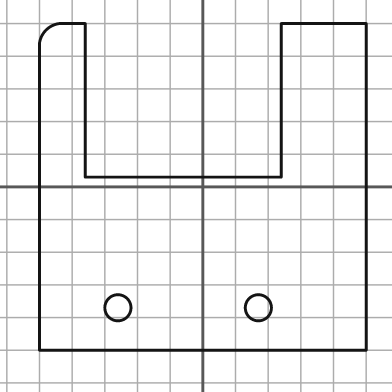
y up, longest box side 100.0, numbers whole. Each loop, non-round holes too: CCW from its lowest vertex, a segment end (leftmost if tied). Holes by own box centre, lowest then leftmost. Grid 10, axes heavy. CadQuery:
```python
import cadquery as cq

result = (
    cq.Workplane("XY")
    .moveTo(-50.0, -50.0)
    .lineTo(50.0, -50.0)
    .lineTo(50.0, 50.0)
    .lineTo(24.0, 50.0)
    .lineTo(24.0, 3.0)
    .lineTo(-36.0, 3.0)
    .lineTo(-36.0, 50.0)
    .lineTo(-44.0, 50.0)
    .threePointArc((-48.0, 48.0), (-50.0, 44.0))
    .close()
    .moveTo(-26.0, -37.0)
    .circle(4.0)
    .moveTo(17.0, -37.0)
    .circle(4.0)
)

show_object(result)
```